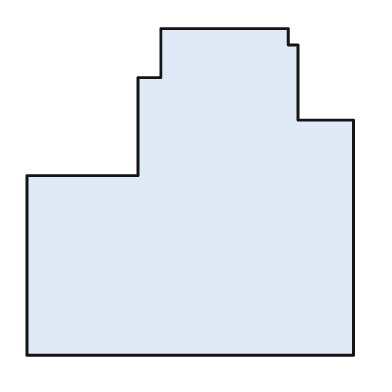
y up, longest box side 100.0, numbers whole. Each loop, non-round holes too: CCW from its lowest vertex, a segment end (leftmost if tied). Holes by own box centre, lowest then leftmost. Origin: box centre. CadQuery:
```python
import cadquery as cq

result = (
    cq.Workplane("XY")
    .moveTo(-50.0, -50.0)
    .lineTo(50.0, -50.0)
    .lineTo(50.0, 22.0)
    .lineTo(33.0, 22.0)
    .lineTo(33.0, 45.0)
    .lineTo(30.0, 45.0)
    .lineTo(30.0, 50.0)
    .lineTo(-9.0, 50.0)
    .lineTo(-9.0, 35.0)
    .lineTo(-16.0, 35.0)
    .lineTo(-16.0, 5.0)
    .lineTo(-50.0, 5.0)
    .close()
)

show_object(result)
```